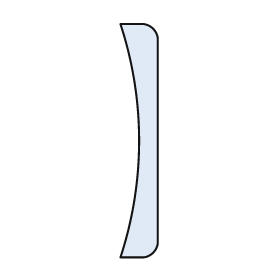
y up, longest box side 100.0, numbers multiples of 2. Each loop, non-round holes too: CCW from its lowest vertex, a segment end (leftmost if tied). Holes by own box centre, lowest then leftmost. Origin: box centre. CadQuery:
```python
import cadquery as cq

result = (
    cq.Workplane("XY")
    .moveTo(-8.0, -50.0)
    .lineTo(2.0, -50.0)
    .threePointArc((6.0, -48.0), (8.0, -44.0))
    .lineTo(8.0, 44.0)
    .threePointArc((6.0, 48.0), (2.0, 50.0))
    .lineTo(-8.0, 50.0)
    .threePointArc((0.0, 0.0), (-8.0, -50.0))
    .close()
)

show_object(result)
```